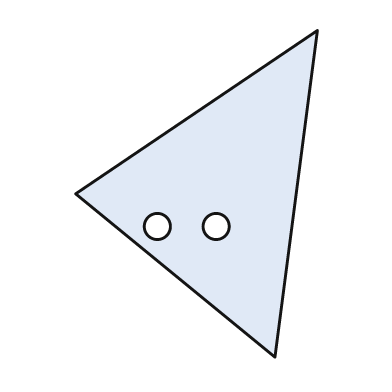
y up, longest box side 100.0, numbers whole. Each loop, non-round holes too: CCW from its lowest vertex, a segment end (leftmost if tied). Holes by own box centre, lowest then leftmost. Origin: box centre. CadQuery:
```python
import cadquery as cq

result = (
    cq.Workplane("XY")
    .moveTo(24.0, -50.0)
    .lineTo(37.0, 50.0)
    .lineTo(-37.0, 0.0)
    .close()
    .moveTo(-12.0, -10.0)
    .circle(4.0)
    .moveTo(6.0, -10.0)
    .circle(4.0)
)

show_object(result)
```